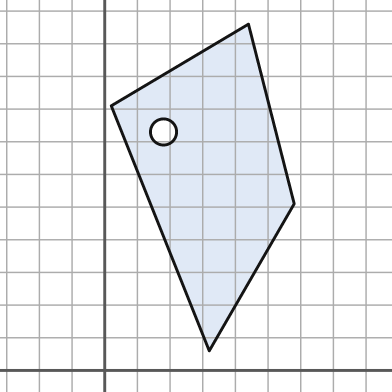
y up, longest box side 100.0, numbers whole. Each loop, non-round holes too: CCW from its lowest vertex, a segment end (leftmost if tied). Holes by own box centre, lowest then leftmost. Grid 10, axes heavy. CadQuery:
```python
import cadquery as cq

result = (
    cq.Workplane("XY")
    .moveTo(32.0, 6.0)
    .lineTo(58.0, 51.0)
    .lineTo(44.0, 106.0)
    .lineTo(2.0, 81.0)
    .close()
    .moveTo(18.0, 73.0)
    .circle(4.0)
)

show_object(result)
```